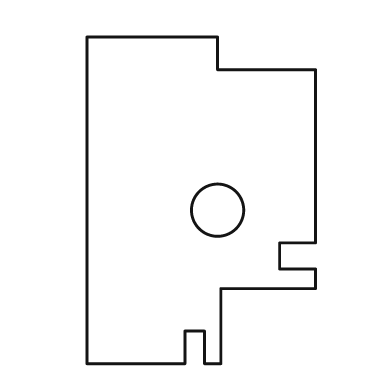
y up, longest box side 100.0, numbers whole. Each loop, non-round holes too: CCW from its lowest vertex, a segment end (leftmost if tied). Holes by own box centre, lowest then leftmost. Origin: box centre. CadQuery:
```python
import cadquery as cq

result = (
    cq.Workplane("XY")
    .moveTo(-35.0, -50.0)
    .lineTo(-5.0, -50.0)
    .lineTo(-5.0, -40.0)
    .lineTo(1.0, -40.0)
    .lineTo(1.0, -50.0)
    .lineTo(6.0, -50.0)
    .lineTo(6.0, -27.0)
    .lineTo(35.0, -27.0)
    .lineTo(35.0, -21.0)
    .lineTo(24.0, -21.0)
    .lineTo(24.0, -13.0)
    .lineTo(35.0, -13.0)
    .lineTo(35.0, 40.0)
    .lineTo(5.0, 40.0)
    .lineTo(5.0, 50.0)
    .lineTo(-35.0, 50.0)
    .close()
    .moveTo(5.0, -3.0)
    .circle(8.0)
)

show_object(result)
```